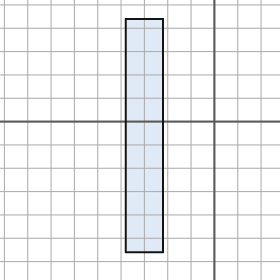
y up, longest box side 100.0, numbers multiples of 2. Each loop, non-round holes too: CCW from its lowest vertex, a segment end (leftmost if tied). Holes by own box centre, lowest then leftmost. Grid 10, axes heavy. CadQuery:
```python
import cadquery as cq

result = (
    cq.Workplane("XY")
    .moveTo(-38.0, -56.0)
    .lineTo(-22.0, -56.0)
    .lineTo(-22.0, 44.0)
    .lineTo(-38.0, 44.0)
    .close()
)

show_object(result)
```